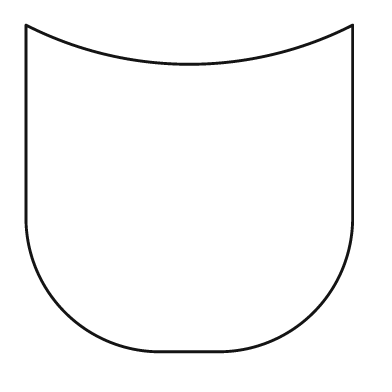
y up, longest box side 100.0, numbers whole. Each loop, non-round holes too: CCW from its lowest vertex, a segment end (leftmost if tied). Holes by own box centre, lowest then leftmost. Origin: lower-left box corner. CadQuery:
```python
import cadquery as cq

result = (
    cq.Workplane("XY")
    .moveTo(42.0, 0.0)
    .lineTo(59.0, 0.0)
    .threePointArc((88.0, 12.0), (100.0, 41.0))
    .lineTo(100.0, 100.0)
    .threePointArc((50.0, 88.0), (0.0, 100.0))
    .lineTo(0.0, 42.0)
    .threePointArc((12.0, 12.0), (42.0, 0.0))
    .close()
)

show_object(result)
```